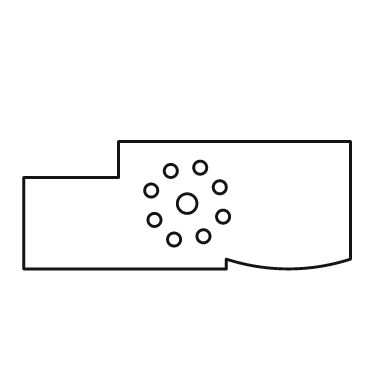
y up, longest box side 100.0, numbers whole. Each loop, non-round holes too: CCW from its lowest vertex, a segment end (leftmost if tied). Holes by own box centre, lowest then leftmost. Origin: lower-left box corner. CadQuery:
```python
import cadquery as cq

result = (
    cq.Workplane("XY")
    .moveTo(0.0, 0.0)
    .lineTo(62.0, 0.0)
    .lineTo(62.0, 3.0)
    .threePointArc((81.0, 0.0), (100.0, 3.0))
    .lineTo(100.0, 39.0)
    .lineTo(29.0, 39.0)
    .lineTo(29.0, 28.0)
    .lineTo(0.0, 28.0)
    .close()
    .moveTo(46.0, 9.0)
    .circle(2.0)
    .moveTo(55.0, 10.0)
    .circle(2.0)
    .moveTo(40.0, 15.0)
    .circle(2.0)
    .moveTo(61.0, 16.0)
    .circle(2.0)
    .moveTo(50.0, 20.0)
    .circle(3.0)
    .moveTo(39.0, 24.0)
    .circle(2.0)
    .moveTo(60.0, 25.0)
    .circle(2.0)
    .moveTo(45.0, 30.0)
    .circle(2.0)
    .moveTo(54.0, 31.0)
    .circle(2.0)
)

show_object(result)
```